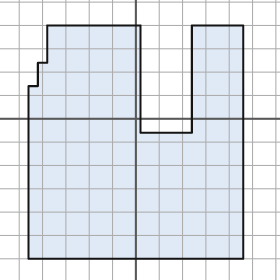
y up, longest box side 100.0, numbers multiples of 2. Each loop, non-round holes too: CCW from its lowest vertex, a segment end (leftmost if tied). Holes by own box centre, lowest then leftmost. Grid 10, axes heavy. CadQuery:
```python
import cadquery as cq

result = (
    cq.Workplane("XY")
    .moveTo(-46.0, -60.0)
    .lineTo(46.0, -60.0)
    .lineTo(46.0, 40.0)
    .lineTo(24.0, 40.0)
    .lineTo(24.0, -6.0)
    .lineTo(2.0, -6.0)
    .lineTo(2.0, 40.0)
    .lineTo(-38.0, 40.0)
    .lineTo(-38.0, 24.0)
    .lineTo(-42.0, 24.0)
    .lineTo(-42.0, 14.0)
    .lineTo(-46.0, 14.0)
    .close()
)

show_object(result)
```